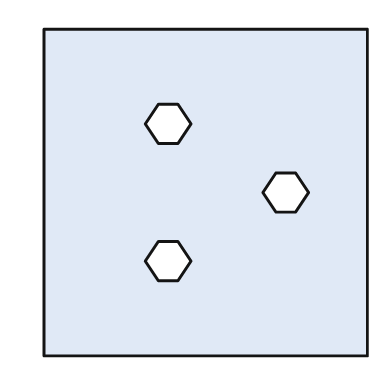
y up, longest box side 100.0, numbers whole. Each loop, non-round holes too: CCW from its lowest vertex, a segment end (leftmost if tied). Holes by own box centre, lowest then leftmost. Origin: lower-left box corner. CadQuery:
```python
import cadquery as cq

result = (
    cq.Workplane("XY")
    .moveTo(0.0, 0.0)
    .lineTo(99.0, 0.0)
    .lineTo(99.0, 100.0)
    .lineTo(0.0, 100.0)
    .close()
    .moveTo(35.0, 23.0)
    .lineTo(41.0, 23.0)
    .lineTo(45.0, 29.0)
    .lineTo(41.0, 35.0)
    .lineTo(35.0, 35.0)
    .lineTo(31.0, 29.0)
    .close()
    .moveTo(71.0, 44.0)
    .lineTo(77.0, 44.0)
    .lineTo(81.0, 50.0)
    .lineTo(77.0, 56.0)
    .lineTo(71.0, 56.0)
    .lineTo(67.0, 50.0)
    .close()
    .moveTo(35.0, 65.0)
    .lineTo(41.0, 65.0)
    .lineTo(45.0, 71.0)
    .lineTo(41.0, 77.0)
    .lineTo(35.0, 77.0)
    .lineTo(31.0, 71.0)
    .close()
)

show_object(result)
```